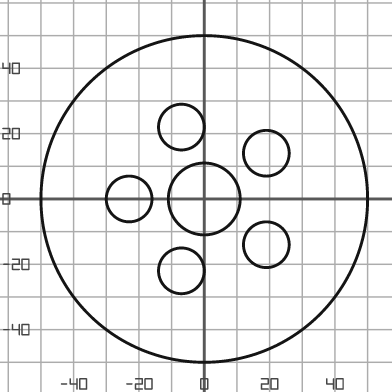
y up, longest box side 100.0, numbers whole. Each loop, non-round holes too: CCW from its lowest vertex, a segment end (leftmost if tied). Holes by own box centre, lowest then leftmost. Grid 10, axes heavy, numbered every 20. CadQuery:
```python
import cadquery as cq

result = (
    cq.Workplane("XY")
    .moveTo(0.0, 0.0)
    .circle(50.0)
    .moveTo(-7.0, -22.0)
    .circle(7.0)
    .moveTo(19.0, -14.0)
    .circle(7.0)
    .moveTo(-23.0, 0.0)
    .circle(7.0)
    .moveTo(0.0, 0.0)
    .circle(11.0)
    .moveTo(19.0, 14.0)
    .circle(7.0)
    .moveTo(-7.0, 22.0)
    .circle(7.0)
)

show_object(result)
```